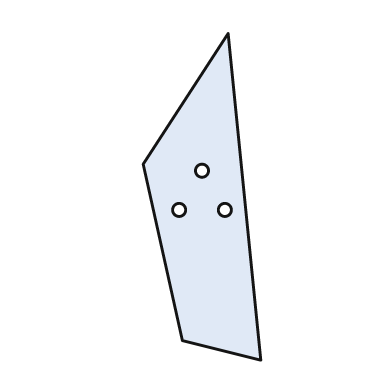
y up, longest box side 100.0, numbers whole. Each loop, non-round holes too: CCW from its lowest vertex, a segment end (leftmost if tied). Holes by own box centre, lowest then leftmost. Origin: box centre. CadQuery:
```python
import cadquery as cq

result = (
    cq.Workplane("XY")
    .moveTo(18.0, -50.0)
    .lineTo(8.0, 50.0)
    .lineTo(-18.0, 10.0)
    .lineTo(-6.0, -44.0)
    .close()
    .moveTo(-7.0, -4.0)
    .circle(2.0)
    .moveTo(7.0, -4.0)
    .circle(2.0)
    .moveTo(0.0, 8.0)
    .circle(2.0)
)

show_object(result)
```